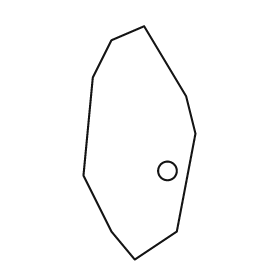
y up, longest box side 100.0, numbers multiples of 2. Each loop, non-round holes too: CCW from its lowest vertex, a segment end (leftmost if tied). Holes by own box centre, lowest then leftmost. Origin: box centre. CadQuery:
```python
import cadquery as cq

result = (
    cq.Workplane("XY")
    .moveTo(-2.0, -50.0)
    .lineTo(16.0, -38.0)
    .lineTo(24.0, 4.0)
    .lineTo(20.0, 20.0)
    .lineTo(2.0, 50.0)
    .lineTo(-12.0, 44.0)
    .lineTo(-20.0, 28.0)
    .lineTo(-24.0, -14.0)
    .lineTo(-12.0, -38.0)
    .close()
    .moveTo(12.0, -12.0)
    .circle(4.0)
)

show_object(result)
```